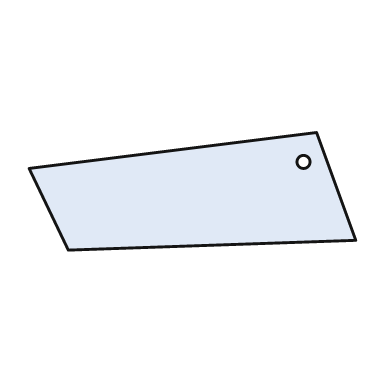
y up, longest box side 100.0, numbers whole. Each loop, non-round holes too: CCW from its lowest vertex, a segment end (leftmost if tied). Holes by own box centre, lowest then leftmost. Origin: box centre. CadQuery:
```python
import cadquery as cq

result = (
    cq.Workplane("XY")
    .moveTo(-38.0, -18.0)
    .lineTo(50.0, -15.0)
    .lineTo(38.0, 18.0)
    .lineTo(-50.0, 7.0)
    .close()
    .moveTo(34.0, 9.0)
    .circle(2.0)
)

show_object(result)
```